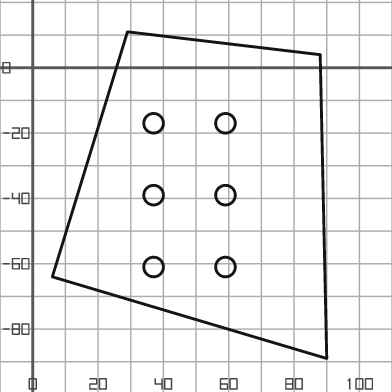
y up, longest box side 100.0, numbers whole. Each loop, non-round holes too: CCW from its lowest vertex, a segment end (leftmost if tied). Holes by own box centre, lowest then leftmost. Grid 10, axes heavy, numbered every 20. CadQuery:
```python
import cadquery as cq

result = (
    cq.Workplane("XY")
    .moveTo(90.0, -89.0)
    .lineTo(88.0, 4.0)
    .lineTo(29.0, 11.0)
    .lineTo(6.0, -64.0)
    .close()
    .moveTo(37.0, -61.0)
    .circle(3.0)
    .moveTo(59.0, -61.0)
    .circle(3.0)
    .moveTo(37.0, -39.0)
    .circle(3.0)
    .moveTo(59.0, -39.0)
    .circle(3.0)
    .moveTo(37.0, -17.0)
    .circle(3.0)
    .moveTo(59.0, -17.0)
    .circle(3.0)
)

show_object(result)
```